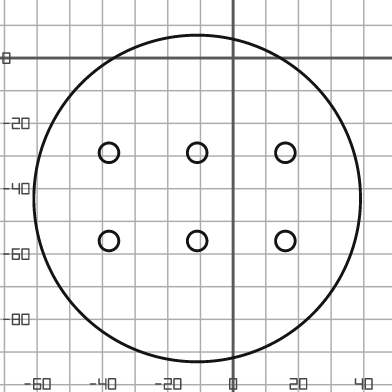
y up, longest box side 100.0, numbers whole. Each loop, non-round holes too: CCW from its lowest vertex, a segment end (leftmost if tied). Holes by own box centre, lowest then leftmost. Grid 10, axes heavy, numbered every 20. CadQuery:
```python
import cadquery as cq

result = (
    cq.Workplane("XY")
    .moveTo(-11.0, -43.0)
    .circle(50.0)
    .moveTo(-38.0, -56.0)
    .circle(3.0)
    .moveTo(-11.0, -56.0)
    .circle(3.0)
    .moveTo(16.0, -56.0)
    .circle(3.0)
    .moveTo(-38.0, -29.0)
    .circle(3.0)
    .moveTo(-11.0, -29.0)
    .circle(3.0)
    .moveTo(16.0, -29.0)
    .circle(3.0)
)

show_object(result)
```